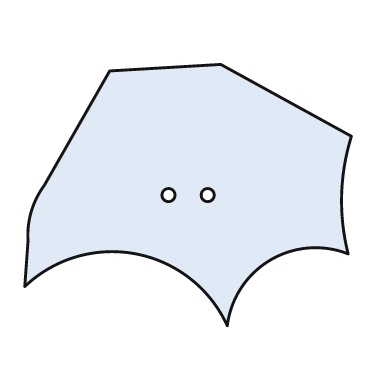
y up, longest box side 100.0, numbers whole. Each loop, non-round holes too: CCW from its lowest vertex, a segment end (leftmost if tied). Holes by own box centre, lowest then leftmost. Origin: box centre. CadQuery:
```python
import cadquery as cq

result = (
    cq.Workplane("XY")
    .moveTo(12.0, -40.0)
    .threePointArc((25.0, -20.0), (49.0, -18.0))
    .threePointArc((47.0, 0.0), (50.0, 18.0))
    .lineTo(10.0, 40.0)
    .lineTo(-24.0, 38.0)
    .lineTo(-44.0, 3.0)
    .threePointArc((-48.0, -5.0), (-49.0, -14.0))
    .lineTo(-50.0, -28.0)
    .threePointArc((-16.0, -18.0), (12.0, -40.0))
    .close()
    .moveTo(-6.0, 0.0)
    .circle(2.0)
    .moveTo(6.0, 0.0)
    .circle(2.0)
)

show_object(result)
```